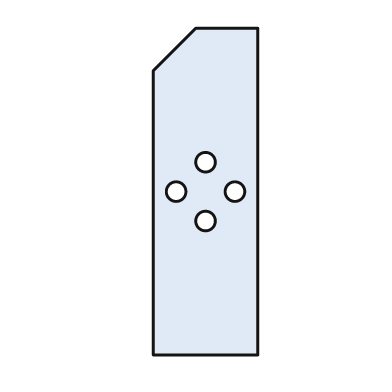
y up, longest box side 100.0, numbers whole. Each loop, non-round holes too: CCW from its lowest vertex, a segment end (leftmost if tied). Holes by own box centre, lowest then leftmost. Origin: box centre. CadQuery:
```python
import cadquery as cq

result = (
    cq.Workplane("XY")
    .moveTo(-16.0, -50.0)
    .lineTo(16.0, -50.0)
    .lineTo(16.0, 50.0)
    .lineTo(-3.0, 50.0)
    .lineTo(-16.0, 37.0)
    .close()
    .moveTo(0.0, -9.0)
    .circle(3.0)
    .moveTo(-9.0, 0.0)
    .circle(3.0)
    .moveTo(9.0, 0.0)
    .circle(3.0)
    .moveTo(0.0, 9.0)
    .circle(3.0)
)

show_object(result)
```